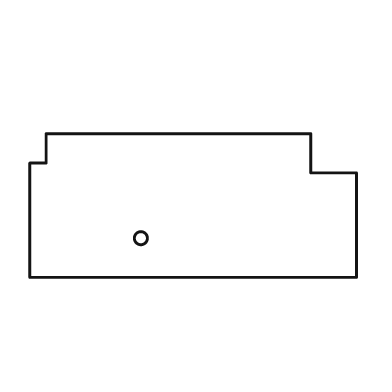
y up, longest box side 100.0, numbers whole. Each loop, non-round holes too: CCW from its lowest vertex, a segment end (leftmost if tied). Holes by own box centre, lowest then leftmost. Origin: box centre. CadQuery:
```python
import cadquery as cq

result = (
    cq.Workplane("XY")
    .moveTo(-50.0, -22.0)
    .lineTo(50.0, -22.0)
    .lineTo(50.0, 10.0)
    .lineTo(36.0, 10.0)
    .lineTo(36.0, 22.0)
    .lineTo(-45.0, 22.0)
    .lineTo(-45.0, 13.0)
    .lineTo(-50.0, 13.0)
    .close()
    .moveTo(-16.0, -10.0)
    .circle(2.0)
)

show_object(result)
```